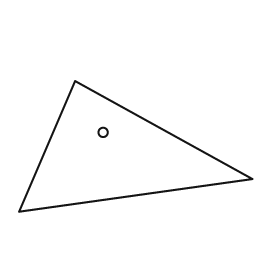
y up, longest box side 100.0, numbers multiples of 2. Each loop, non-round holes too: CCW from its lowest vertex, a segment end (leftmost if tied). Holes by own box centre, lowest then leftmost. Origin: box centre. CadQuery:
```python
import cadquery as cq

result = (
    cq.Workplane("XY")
    .moveTo(-50.0, -28.0)
    .lineTo(50.0, -14.0)
    .lineTo(-26.0, 28.0)
    .close()
    .moveTo(-14.0, 6.0)
    .circle(2.0)
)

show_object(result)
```